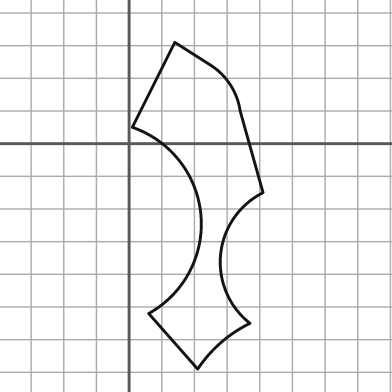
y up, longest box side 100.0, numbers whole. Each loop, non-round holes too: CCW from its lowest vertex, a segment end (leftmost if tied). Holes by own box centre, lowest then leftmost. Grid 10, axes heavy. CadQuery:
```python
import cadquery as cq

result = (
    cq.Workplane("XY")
    .moveTo(21.0, -69.0)
    .threePointArc((28.0, -61.0), (37.0, -55.0))
    .threePointArc((28.0, -34.0), (41.0, -15.0))
    .lineTo(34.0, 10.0)
    .threePointArc((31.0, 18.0), (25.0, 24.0))
    .lineTo(14.0, 31.0)
    .lineTo(1.0, 5.0)
    .threePointArc((22.0, -22.0), (6.0, -52.0))
    .close()
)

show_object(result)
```